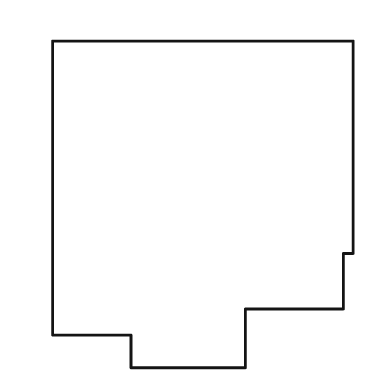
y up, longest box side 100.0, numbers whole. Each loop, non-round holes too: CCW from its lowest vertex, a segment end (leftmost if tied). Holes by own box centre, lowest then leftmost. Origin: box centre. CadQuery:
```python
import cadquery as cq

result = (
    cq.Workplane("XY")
    .moveTo(-22.0, -50.0)
    .lineTo(13.0, -50.0)
    .lineTo(13.0, -32.0)
    .lineTo(43.0, -32.0)
    .lineTo(43.0, -15.0)
    .lineTo(46.0, -15.0)
    .lineTo(46.0, 50.0)
    .lineTo(-46.0, 50.0)
    .lineTo(-46.0, -40.0)
    .lineTo(-22.0, -40.0)
    .close()
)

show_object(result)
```